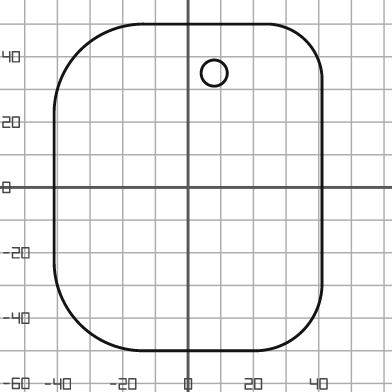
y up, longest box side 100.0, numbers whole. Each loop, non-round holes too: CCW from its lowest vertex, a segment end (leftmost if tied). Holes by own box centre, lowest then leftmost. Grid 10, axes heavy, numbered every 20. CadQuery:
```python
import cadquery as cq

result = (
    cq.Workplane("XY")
    .moveTo(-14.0, -50.0)
    .lineTo(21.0, -50.0)
    .threePointArc((35.0, -44.0), (41.0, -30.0))
    .lineTo(41.0, 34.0)
    .threePointArc((36.0, 45.0), (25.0, 50.0))
    .lineTo(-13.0, 50.0)
    .threePointArc((-33.0, 42.0), (-41.0, 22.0))
    .lineTo(-41.0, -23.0)
    .threePointArc((-33.0, -42.0), (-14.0, -50.0))
    .close()
    .moveTo(8.0, 35.0)
    .circle(4.0)
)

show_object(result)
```